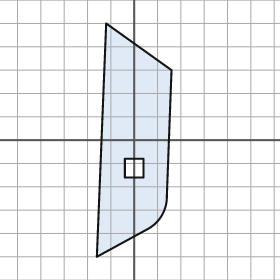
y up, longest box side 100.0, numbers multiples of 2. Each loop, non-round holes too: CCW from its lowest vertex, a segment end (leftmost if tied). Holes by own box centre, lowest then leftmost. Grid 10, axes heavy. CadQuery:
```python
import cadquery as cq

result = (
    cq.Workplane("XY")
    .moveTo(-16.0, -50.0)
    .lineTo(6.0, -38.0)
    .threePointArc((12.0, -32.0), (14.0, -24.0))
    .lineTo(16.0, 30.0)
    .lineTo(-12.0, 50.0)
    .close()
    .moveTo(-4.0, -16.0)
    .lineTo(4.0, -16.0)
    .lineTo(4.0, -8.0)
    .lineTo(-4.0, -8.0)
    .close()
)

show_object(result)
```